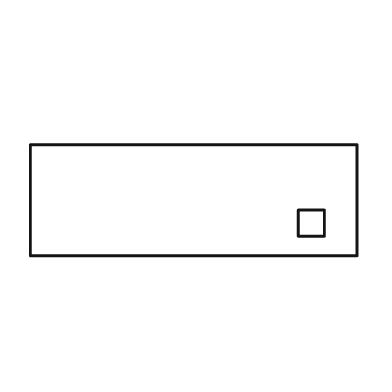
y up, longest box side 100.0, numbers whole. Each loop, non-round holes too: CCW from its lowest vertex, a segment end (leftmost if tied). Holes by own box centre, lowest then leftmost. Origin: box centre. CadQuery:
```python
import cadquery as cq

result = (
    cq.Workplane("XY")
    .moveTo(-50.0, -17.0)
    .lineTo(50.0, -17.0)
    .lineTo(50.0, 17.0)
    .lineTo(-50.0, 17.0)
    .close()
    .moveTo(32.0, -11.0)
    .lineTo(40.0, -11.0)
    .lineTo(40.0, -3.0)
    .lineTo(32.0, -3.0)
    .close()
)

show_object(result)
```